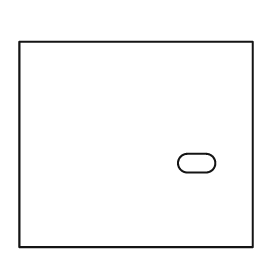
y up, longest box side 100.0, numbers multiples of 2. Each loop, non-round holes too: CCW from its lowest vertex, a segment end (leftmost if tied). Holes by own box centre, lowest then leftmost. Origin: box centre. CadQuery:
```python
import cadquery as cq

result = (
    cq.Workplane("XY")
    .moveTo(-50.0, -44.0)
    .lineTo(50.0, -44.0)
    .lineTo(50.0, 44.0)
    .lineTo(-50.0, 44.0)
    .close()
    .moveTo(22.0, -12.0)
    .lineTo(30.0, -12.0)
    .threePointArc((34.0, -8.0), (30.0, -4.0))
    .lineTo(22.0, -4.0)
    .threePointArc((18.0, -8.0), (22.0, -12.0))
    .close()
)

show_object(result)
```